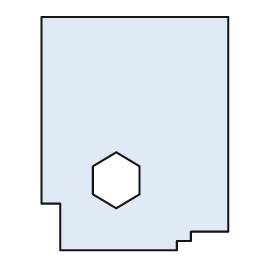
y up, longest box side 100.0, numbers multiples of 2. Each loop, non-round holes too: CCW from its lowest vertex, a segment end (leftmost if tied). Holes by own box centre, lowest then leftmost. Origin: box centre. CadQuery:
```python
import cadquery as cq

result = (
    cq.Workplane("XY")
    .moveTo(-32.0, -50.0)
    .lineTo(18.0, -50.0)
    .lineTo(18.0, -46.0)
    .lineTo(24.0, -46.0)
    .lineTo(24.0, -42.0)
    .lineTo(40.0, -42.0)
    .lineTo(40.0, 50.0)
    .lineTo(-40.0, 50.0)
    .lineTo(-40.0, -30.0)
    .lineTo(-32.0, -30.0)
    .close()
    .moveTo(-8.0, -32.0)
    .lineTo(2.0, -26.0)
    .lineTo(2.0, -14.0)
    .lineTo(-8.0, -8.0)
    .lineTo(-18.0, -14.0)
    .lineTo(-18.0, -26.0)
    .close()
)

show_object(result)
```